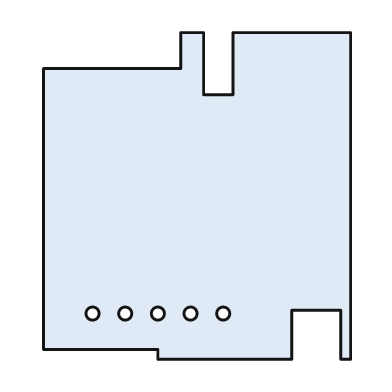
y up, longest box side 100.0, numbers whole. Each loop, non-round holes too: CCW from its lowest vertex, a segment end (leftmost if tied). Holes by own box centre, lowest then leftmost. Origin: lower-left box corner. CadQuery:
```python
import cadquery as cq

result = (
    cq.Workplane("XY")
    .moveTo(35.0, 0.0)
    .lineTo(76.0, 0.0)
    .lineTo(76.0, 15.0)
    .lineTo(91.0, 15.0)
    .lineTo(91.0, 0.0)
    .lineTo(94.0, 0.0)
    .lineTo(94.0, 100.0)
    .lineTo(58.0, 100.0)
    .lineTo(58.0, 81.0)
    .lineTo(49.0, 81.0)
    .lineTo(49.0, 100.0)
    .lineTo(42.0, 100.0)
    .lineTo(42.0, 89.0)
    .lineTo(0.0, 89.0)
    .lineTo(0.0, 3.0)
    .lineTo(35.0, 3.0)
    .close()
    .moveTo(15.0, 14.0)
    .circle(2.0)
    .moveTo(25.0, 14.0)
    .circle(2.0)
    .moveTo(35.0, 14.0)
    .circle(2.0)
    .moveTo(45.0, 14.0)
    .circle(2.0)
    .moveTo(55.0, 14.0)
    .circle(2.0)
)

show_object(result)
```